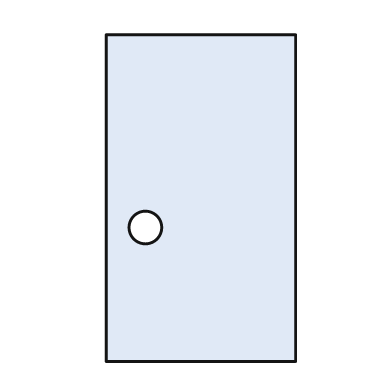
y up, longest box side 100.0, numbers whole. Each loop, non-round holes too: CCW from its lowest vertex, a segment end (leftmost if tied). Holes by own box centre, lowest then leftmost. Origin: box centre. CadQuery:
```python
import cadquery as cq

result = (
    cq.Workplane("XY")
    .moveTo(-29.0, -50.0)
    .lineTo(29.0, -50.0)
    .lineTo(29.0, 50.0)
    .lineTo(-29.0, 50.0)
    .close()
    .moveTo(-17.0, -9.0)
    .circle(5.0)
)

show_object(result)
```